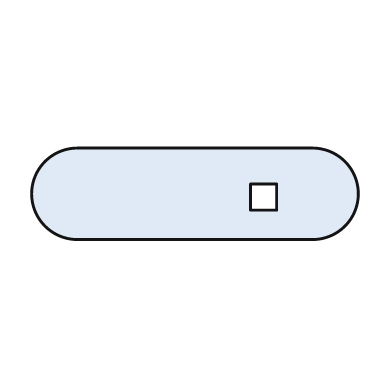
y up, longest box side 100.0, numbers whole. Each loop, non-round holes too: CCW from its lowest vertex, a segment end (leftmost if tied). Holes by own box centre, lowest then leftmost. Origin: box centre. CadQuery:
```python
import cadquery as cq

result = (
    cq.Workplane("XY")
    .moveTo(-36.0, -14.0)
    .lineTo(36.0, -14.0)
    .threePointArc((50.0, 0.0), (36.0, 14.0))
    .lineTo(-36.0, 14.0)
    .threePointArc((-50.0, 0.0), (-36.0, -14.0))
    .close()
    .moveTo(17.0, -5.0)
    .lineTo(25.0, -5.0)
    .lineTo(25.0, 3.0)
    .lineTo(17.0, 3.0)
    .close()
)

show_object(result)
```